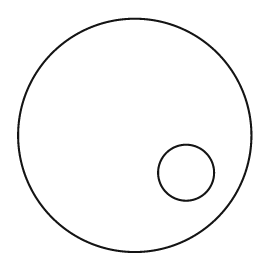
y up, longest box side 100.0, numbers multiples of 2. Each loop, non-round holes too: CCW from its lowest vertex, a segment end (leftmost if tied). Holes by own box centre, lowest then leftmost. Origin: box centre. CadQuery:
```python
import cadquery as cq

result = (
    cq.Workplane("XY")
    .moveTo(0.0, 0.0)
    .circle(50.0)
    .moveTo(22.0, -16.0)
    .circle(12.0)
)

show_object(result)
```